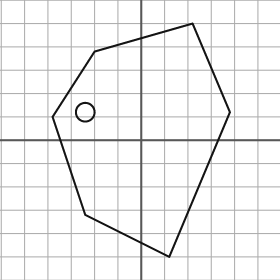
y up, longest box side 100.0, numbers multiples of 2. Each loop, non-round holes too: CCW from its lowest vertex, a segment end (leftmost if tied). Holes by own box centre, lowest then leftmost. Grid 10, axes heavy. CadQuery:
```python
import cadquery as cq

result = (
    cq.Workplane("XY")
    .moveTo(12.0, -50.0)
    .lineTo(38.0, 12.0)
    .lineTo(22.0, 50.0)
    .lineTo(-20.0, 38.0)
    .lineTo(-38.0, 10.0)
    .lineTo(-24.0, -32.0)
    .close()
    .moveTo(-24.0, 12.0)
    .circle(4.0)
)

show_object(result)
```